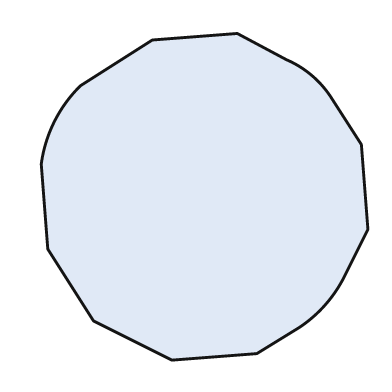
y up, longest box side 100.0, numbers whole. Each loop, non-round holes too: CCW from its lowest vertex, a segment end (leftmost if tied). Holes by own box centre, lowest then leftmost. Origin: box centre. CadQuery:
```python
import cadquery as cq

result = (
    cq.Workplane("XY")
    .moveTo(-10.0, -50.0)
    .lineTo(16.0, -48.0)
    .lineTo(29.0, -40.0)
    .threePointArc((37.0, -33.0), (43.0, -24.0))
    .lineTo(50.0, -10.0)
    .lineTo(48.0, 16.0)
    .lineTo(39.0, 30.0)
    .threePointArc((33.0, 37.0), (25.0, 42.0))
    .lineTo(10.0, 50.0)
    .lineTo(-16.0, 48.0)
    .lineTo(-38.0, 34.0)
    .threePointArc((-46.0, 23.0), (-50.0, 10.0))
    .lineTo(-48.0, -16.0)
    .lineTo(-34.0, -38.0)
    .close()
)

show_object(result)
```